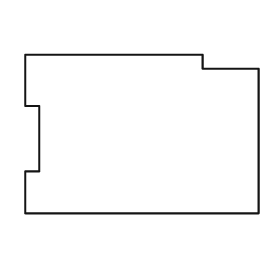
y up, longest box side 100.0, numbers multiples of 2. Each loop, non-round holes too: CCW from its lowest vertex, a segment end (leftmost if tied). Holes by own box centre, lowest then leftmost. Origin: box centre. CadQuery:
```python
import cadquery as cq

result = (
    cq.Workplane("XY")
    .moveTo(-50.0, -34.0)
    .lineTo(50.0, -34.0)
    .lineTo(50.0, 28.0)
    .lineTo(26.0, 28.0)
    .lineTo(26.0, 34.0)
    .lineTo(-50.0, 34.0)
    .lineTo(-50.0, 12.0)
    .lineTo(-44.0, 12.0)
    .lineTo(-44.0, -16.0)
    .lineTo(-50.0, -16.0)
    .close()
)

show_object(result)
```